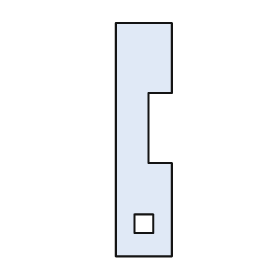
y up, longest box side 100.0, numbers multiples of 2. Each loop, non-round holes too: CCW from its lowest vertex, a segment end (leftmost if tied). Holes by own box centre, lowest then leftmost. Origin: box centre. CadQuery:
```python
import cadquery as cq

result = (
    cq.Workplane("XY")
    .moveTo(-12.0, -50.0)
    .lineTo(12.0, -50.0)
    .lineTo(12.0, -10.0)
    .lineTo(2.0, -10.0)
    .lineTo(2.0, 20.0)
    .lineTo(12.0, 20.0)
    .lineTo(12.0, 50.0)
    .lineTo(-12.0, 50.0)
    .close()
    .moveTo(-4.0, -40.0)
    .lineTo(4.0, -40.0)
    .lineTo(4.0, -32.0)
    .lineTo(-4.0, -32.0)
    .close()
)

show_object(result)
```